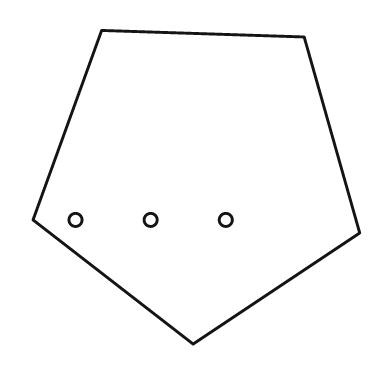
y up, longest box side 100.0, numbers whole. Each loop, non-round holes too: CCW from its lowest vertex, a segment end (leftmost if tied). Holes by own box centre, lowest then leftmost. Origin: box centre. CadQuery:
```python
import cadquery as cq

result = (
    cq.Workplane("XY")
    .moveTo(-1.0, -48.0)
    .lineTo(50.0, -14.0)
    .lineTo(33.0, 46.0)
    .lineTo(-29.0, 48.0)
    .lineTo(-50.0, -10.0)
    .close()
    .moveTo(-37.0, -10.0)
    .circle(2.0)
    .moveTo(-14.0, -10.0)
    .circle(2.0)
    .moveTo(9.0, -10.0)
    .circle(2.0)
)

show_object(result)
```